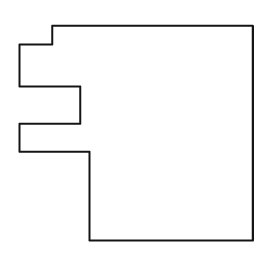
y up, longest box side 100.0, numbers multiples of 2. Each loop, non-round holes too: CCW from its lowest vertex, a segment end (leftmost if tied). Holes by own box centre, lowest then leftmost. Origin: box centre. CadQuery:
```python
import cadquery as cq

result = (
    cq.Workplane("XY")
    .moveTo(-20.0, -46.0)
    .lineTo(50.0, -46.0)
    .lineTo(50.0, 46.0)
    .lineTo(-36.0, 46.0)
    .lineTo(-36.0, 38.0)
    .lineTo(-50.0, 38.0)
    .lineTo(-50.0, 20.0)
    .lineTo(-24.0, 20.0)
    .lineTo(-24.0, 4.0)
    .lineTo(-50.0, 4.0)
    .lineTo(-50.0, -8.0)
    .lineTo(-20.0, -8.0)
    .close()
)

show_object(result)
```